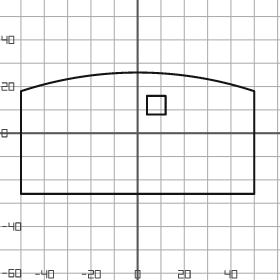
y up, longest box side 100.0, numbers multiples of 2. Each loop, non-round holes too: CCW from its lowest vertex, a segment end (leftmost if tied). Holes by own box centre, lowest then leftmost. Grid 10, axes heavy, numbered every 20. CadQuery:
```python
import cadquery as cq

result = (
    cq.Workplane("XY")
    .moveTo(-50.0, -26.0)
    .lineTo(50.0, -26.0)
    .lineTo(50.0, 18.0)
    .threePointArc((0.0, 26.0), (-50.0, 18.0))
    .close()
    .moveTo(4.0, 8.0)
    .lineTo(12.0, 8.0)
    .lineTo(12.0, 16.0)
    .lineTo(4.0, 16.0)
    .close()
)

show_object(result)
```